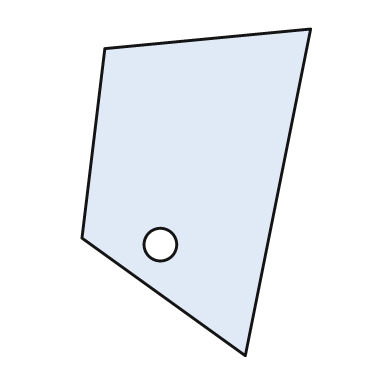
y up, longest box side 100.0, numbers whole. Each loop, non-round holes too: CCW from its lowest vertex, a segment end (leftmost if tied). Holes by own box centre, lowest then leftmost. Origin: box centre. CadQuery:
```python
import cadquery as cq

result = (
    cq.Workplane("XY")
    .moveTo(15.0, -50.0)
    .lineTo(35.0, 50.0)
    .lineTo(-28.0, 44.0)
    .lineTo(-35.0, -14.0)
    .close()
    .moveTo(-11.0, -16.0)
    .circle(5.0)
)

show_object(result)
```